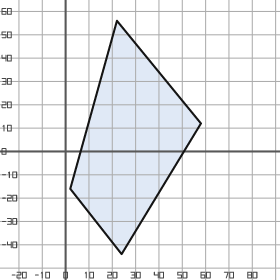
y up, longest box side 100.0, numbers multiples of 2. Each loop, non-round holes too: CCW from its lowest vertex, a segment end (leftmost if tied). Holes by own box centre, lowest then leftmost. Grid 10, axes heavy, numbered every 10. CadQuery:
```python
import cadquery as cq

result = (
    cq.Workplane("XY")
    .moveTo(24.0, -44.0)
    .lineTo(58.0, 12.0)
    .lineTo(22.0, 56.0)
    .lineTo(2.0, -16.0)
    .close()
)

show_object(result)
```